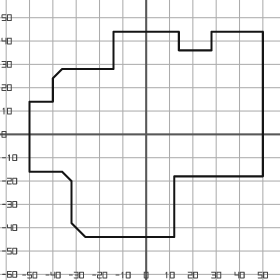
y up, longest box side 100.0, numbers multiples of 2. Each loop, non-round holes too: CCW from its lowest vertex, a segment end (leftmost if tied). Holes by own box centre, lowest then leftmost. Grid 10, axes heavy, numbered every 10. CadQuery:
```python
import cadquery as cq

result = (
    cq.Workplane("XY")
    .moveTo(-26.0, -44.0)
    .lineTo(12.0, -44.0)
    .lineTo(12.0, -18.0)
    .lineTo(50.0, -18.0)
    .lineTo(50.0, 44.0)
    .lineTo(28.0, 44.0)
    .lineTo(28.0, 36.0)
    .lineTo(14.0, 36.0)
    .lineTo(14.0, 44.0)
    .lineTo(-14.0, 44.0)
    .lineTo(-14.0, 28.0)
    .lineTo(-36.0, 28.0)
    .lineTo(-40.0, 24.0)
    .lineTo(-40.0, 14.0)
    .lineTo(-50.0, 14.0)
    .lineTo(-50.0, -16.0)
    .lineTo(-36.0, -16.0)
    .lineTo(-32.0, -20.0)
    .lineTo(-32.0, -38.0)
    .close()
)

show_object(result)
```